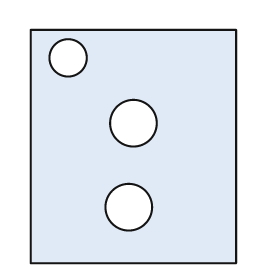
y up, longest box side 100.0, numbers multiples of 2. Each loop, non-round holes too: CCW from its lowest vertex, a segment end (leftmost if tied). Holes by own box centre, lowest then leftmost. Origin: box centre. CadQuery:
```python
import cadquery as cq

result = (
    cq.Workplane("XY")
    .moveTo(-44.0, -50.0)
    .lineTo(44.0, -50.0)
    .lineTo(44.0, 50.0)
    .lineTo(-44.0, 50.0)
    .close()
    .moveTo(-2.0, -26.0)
    .circle(10.0)
    .moveTo(0.0, 10.0)
    .circle(10.0)
    .moveTo(-28.0, 38.0)
    .circle(8.0)
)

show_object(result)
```